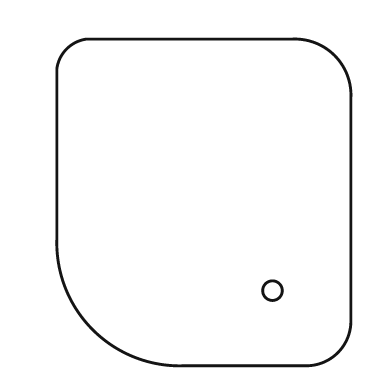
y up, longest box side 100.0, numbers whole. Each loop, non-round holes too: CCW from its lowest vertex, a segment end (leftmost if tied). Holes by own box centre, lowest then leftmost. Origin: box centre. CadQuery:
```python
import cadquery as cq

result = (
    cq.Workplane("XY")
    .moveTo(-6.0, -50.0)
    .lineTo(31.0, -50.0)
    .threePointArc((41.0, -46.0), (45.0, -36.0))
    .lineTo(45.0, 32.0)
    .threePointArc((40.0, 45.0), (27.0, 50.0))
    .lineTo(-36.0, 50.0)
    .threePointArc((-42.0, 47.0), (-45.0, 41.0))
    .lineTo(-45.0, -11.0)
    .threePointArc((-34.0, -39.0), (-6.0, -50.0))
    .close()
    .moveTo(21.0, -27.0)
    .circle(3.0)
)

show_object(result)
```